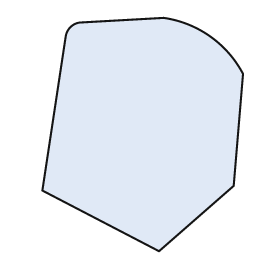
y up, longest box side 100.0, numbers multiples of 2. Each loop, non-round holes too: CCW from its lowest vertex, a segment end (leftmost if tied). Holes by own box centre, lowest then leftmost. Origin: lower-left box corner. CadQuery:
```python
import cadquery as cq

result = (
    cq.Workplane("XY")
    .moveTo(50.0, 0.0)
    .lineTo(82.0, 28.0)
    .lineTo(86.0, 76.0)
    .threePointArc((72.0, 92.0), (52.0, 100.0))
    .lineTo(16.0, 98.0)
    .threePointArc((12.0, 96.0), (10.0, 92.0))
    .lineTo(0.0, 26.0)
    .close()
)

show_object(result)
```